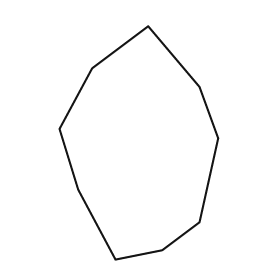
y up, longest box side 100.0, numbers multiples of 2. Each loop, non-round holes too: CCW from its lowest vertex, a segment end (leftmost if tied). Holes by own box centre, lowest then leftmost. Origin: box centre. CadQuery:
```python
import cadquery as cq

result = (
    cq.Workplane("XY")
    .moveTo(-10.0, -50.0)
    .lineTo(10.0, -46.0)
    .lineTo(26.0, -34.0)
    .lineTo(34.0, 2.0)
    .lineTo(26.0, 24.0)
    .lineTo(4.0, 50.0)
    .lineTo(-20.0, 32.0)
    .lineTo(-34.0, 6.0)
    .lineTo(-26.0, -20.0)
    .close()
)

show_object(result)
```